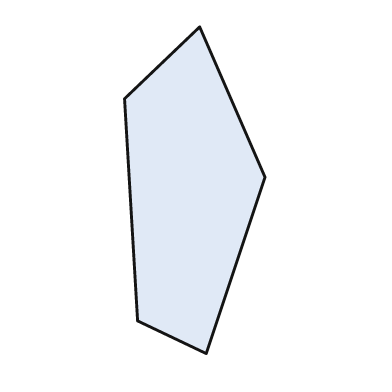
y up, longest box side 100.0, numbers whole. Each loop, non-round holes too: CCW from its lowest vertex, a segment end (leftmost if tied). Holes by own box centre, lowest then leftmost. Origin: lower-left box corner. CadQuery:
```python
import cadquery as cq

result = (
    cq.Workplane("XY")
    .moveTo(25.0, 0.0)
    .lineTo(43.0, 54.0)
    .lineTo(23.0, 100.0)
    .lineTo(0.0, 78.0)
    .lineTo(4.0, 10.0)
    .close()
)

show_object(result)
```